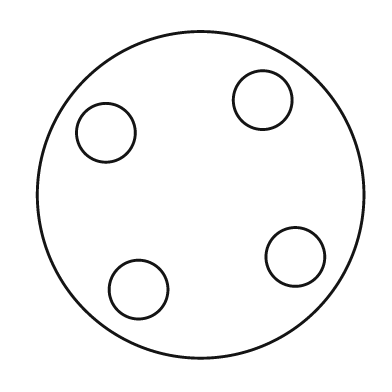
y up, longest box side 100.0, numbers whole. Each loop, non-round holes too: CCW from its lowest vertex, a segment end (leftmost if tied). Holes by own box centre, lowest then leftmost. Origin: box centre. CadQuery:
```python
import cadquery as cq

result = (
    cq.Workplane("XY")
    .moveTo(0.0, 0.0)
    .circle(50.0)
    .moveTo(-19.0, -29.0)
    .circle(9.0)
    .moveTo(29.0, -19.0)
    .circle(9.0)
    .moveTo(-29.0, 19.0)
    .circle(9.0)
    .moveTo(19.0, 29.0)
    .circle(9.0)
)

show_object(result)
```